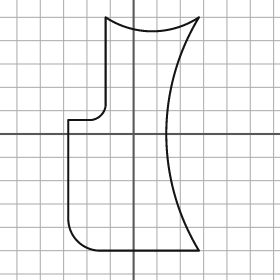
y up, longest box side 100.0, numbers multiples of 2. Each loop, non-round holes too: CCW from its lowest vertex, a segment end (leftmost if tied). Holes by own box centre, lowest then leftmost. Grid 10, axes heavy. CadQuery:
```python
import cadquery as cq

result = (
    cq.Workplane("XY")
    .moveTo(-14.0, -50.0)
    .lineTo(28.0, -50.0)
    .threePointArc((14.0, 0.0), (28.0, 50.0))
    .threePointArc((8.0, 44.0), (-12.0, 50.0))
    .lineTo(-12.0, 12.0)
    .threePointArc((-14.0, 8.0), (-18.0, 6.0))
    .lineTo(-28.0, 6.0)
    .lineTo(-28.0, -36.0)
    .threePointArc((-24.0, -46.0), (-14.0, -50.0))
    .close()
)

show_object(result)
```